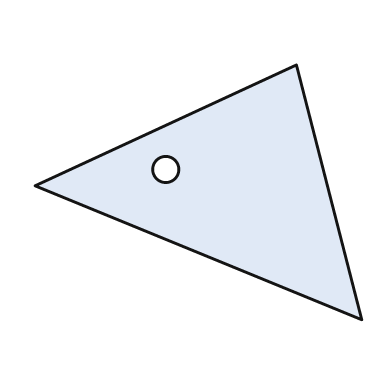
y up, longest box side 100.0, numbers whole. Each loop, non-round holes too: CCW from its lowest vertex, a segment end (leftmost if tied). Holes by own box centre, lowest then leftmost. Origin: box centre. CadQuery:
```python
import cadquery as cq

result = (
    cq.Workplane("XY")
    .moveTo(50.0, -39.0)
    .lineTo(30.0, 39.0)
    .lineTo(-50.0, 2.0)
    .close()
    .moveTo(-10.0, 7.0)
    .circle(4.0)
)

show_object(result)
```